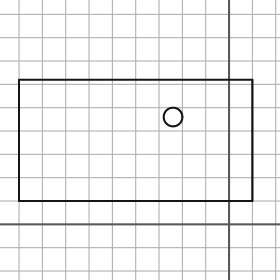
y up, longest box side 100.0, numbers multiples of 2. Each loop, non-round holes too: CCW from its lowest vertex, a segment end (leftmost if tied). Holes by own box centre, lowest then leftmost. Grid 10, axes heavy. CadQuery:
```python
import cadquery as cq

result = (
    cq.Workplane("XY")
    .moveTo(-90.0, 10.0)
    .lineTo(10.0, 10.0)
    .lineTo(10.0, 62.0)
    .lineTo(-90.0, 62.0)
    .close()
    .moveTo(-24.0, 46.0)
    .circle(4.0)
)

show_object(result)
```